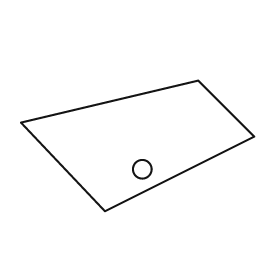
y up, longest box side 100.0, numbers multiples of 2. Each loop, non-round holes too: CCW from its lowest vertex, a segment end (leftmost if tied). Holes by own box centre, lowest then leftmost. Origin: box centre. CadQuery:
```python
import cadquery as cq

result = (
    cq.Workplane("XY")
    .moveTo(-14.0, -28.0)
    .lineTo(50.0, 4.0)
    .lineTo(26.0, 28.0)
    .lineTo(-50.0, 10.0)
    .close()
    .moveTo(2.0, -10.0)
    .circle(4.0)
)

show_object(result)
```